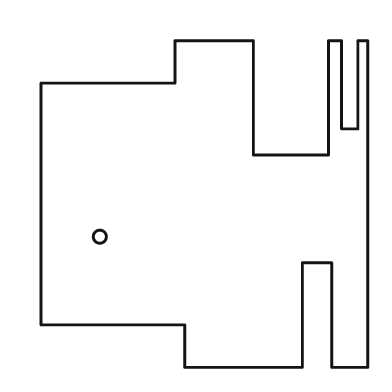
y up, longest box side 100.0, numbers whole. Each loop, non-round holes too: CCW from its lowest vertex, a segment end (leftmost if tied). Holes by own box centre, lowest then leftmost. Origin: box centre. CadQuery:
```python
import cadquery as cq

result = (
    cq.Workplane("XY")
    .moveTo(-6.0, -50.0)
    .lineTo(30.0, -50.0)
    .lineTo(30.0, -18.0)
    .lineTo(39.0, -18.0)
    .lineTo(39.0, -50.0)
    .lineTo(50.0, -50.0)
    .lineTo(50.0, 50.0)
    .lineTo(47.0, 50.0)
    .lineTo(47.0, 23.0)
    .lineTo(42.0, 23.0)
    .lineTo(42.0, 50.0)
    .lineTo(38.0, 50.0)
    .lineTo(38.0, 15.0)
    .lineTo(15.0, 15.0)
    .lineTo(15.0, 50.0)
    .lineTo(-9.0, 50.0)
    .lineTo(-9.0, 37.0)
    .lineTo(-50.0, 37.0)
    .lineTo(-50.0, -37.0)
    .lineTo(-6.0, -37.0)
    .close()
    .moveTo(-32.0, -10.0)
    .circle(2.0)
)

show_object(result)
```